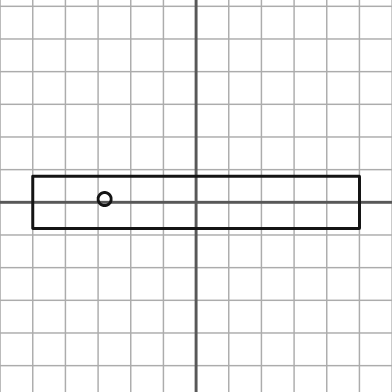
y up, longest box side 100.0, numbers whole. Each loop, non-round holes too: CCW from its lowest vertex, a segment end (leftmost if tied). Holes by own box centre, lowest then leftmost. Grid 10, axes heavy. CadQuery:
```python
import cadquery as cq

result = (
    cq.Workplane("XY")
    .moveTo(-50.0, -8.0)
    .lineTo(50.0, -8.0)
    .lineTo(50.0, 8.0)
    .lineTo(-50.0, 8.0)
    .close()
    .moveTo(-28.0, 1.0)
    .circle(2.0)
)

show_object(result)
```